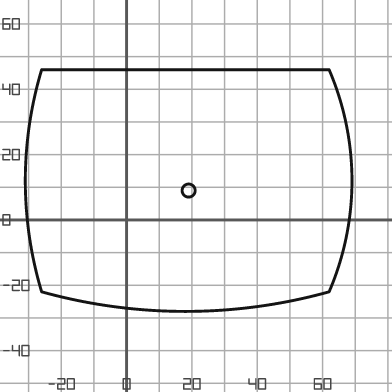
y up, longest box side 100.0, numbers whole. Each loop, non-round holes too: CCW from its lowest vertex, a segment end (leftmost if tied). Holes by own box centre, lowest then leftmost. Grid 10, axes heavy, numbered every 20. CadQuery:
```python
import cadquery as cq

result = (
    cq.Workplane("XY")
    .moveTo(-26.0, -22.0)
    .threePointArc((18.0, -28.0), (62.0, -22.0))
    .threePointArc((69.0, 12.0), (62.0, 46.0))
    .lineTo(-26.0, 46.0)
    .threePointArc((-31.0, 12.0), (-26.0, -22.0))
    .close()
    .moveTo(19.0, 9.0)
    .circle(2.0)
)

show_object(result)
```